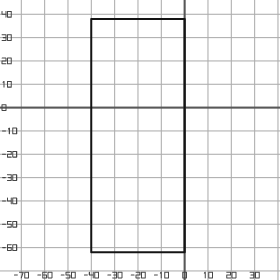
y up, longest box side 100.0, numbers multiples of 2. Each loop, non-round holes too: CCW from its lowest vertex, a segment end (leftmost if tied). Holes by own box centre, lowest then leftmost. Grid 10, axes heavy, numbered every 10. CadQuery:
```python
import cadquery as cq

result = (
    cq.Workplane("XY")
    .moveTo(-40.0, -62.0)
    .lineTo(0.0, -62.0)
    .lineTo(0.0, 38.0)
    .lineTo(-40.0, 38.0)
    .close()
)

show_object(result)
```